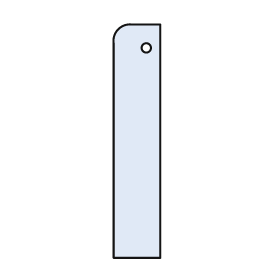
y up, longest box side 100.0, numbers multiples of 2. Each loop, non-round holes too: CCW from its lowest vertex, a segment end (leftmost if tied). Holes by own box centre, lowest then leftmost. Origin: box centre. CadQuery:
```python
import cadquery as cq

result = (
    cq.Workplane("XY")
    .moveTo(-10.0, -50.0)
    .lineTo(10.0, -50.0)
    .lineTo(10.0, 50.0)
    .lineTo(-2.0, 50.0)
    .threePointArc((-8.0, 48.0), (-10.0, 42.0))
    .close()
    .moveTo(4.0, 40.0)
    .circle(2.0)
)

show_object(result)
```